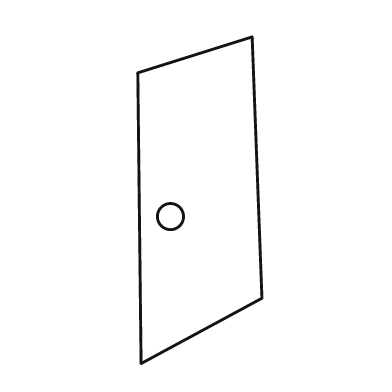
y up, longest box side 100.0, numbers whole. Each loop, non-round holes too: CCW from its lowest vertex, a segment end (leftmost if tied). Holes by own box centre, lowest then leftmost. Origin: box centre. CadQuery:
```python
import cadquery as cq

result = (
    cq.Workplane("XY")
    .moveTo(-18.0, -50.0)
    .lineTo(19.0, -30.0)
    .lineTo(16.0, 50.0)
    .lineTo(-19.0, 39.0)
    .close()
    .moveTo(-9.0, -5.0)
    .circle(4.0)
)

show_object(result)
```